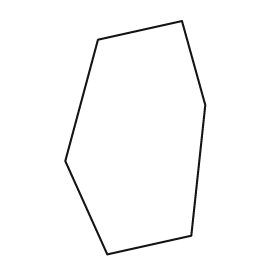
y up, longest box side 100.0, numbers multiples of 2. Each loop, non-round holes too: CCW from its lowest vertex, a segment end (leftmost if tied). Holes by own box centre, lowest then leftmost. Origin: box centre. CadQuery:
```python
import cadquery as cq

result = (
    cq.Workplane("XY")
    .moveTo(-12.0, -50.0)
    .lineTo(24.0, -42.0)
    .lineTo(30.0, 14.0)
    .lineTo(20.0, 50.0)
    .lineTo(-16.0, 42.0)
    .lineTo(-30.0, -10.0)
    .close()
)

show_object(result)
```